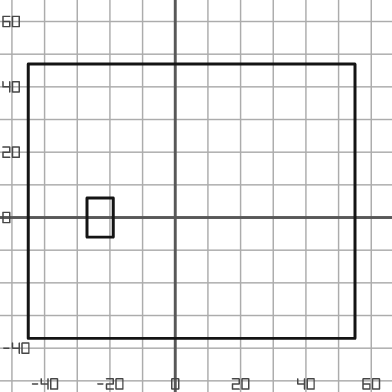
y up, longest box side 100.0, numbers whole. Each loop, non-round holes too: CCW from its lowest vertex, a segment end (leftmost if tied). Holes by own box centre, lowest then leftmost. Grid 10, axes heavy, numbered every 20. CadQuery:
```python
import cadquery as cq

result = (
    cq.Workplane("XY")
    .moveTo(-45.0, -37.0)
    .lineTo(55.0, -37.0)
    .lineTo(55.0, 47.0)
    .lineTo(-45.0, 47.0)
    .close()
    .moveTo(-27.0, -6.0)
    .lineTo(-19.0, -6.0)
    .lineTo(-19.0, 6.0)
    .lineTo(-27.0, 6.0)
    .close()
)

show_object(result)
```